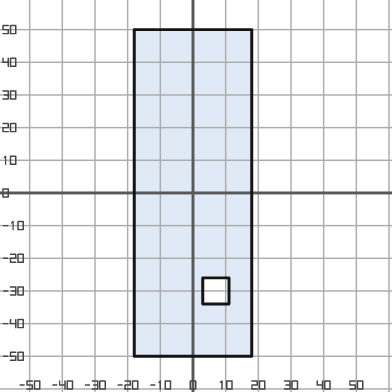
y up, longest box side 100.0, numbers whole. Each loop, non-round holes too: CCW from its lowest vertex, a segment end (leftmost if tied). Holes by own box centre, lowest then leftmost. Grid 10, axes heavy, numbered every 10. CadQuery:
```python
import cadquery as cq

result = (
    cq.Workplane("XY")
    .moveTo(-18.0, -50.0)
    .lineTo(18.0, -50.0)
    .lineTo(18.0, 50.0)
    .lineTo(-18.0, 50.0)
    .close()
    .moveTo(3.0, -34.0)
    .lineTo(11.0, -34.0)
    .lineTo(11.0, -26.0)
    .lineTo(3.0, -26.0)
    .close()
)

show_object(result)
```